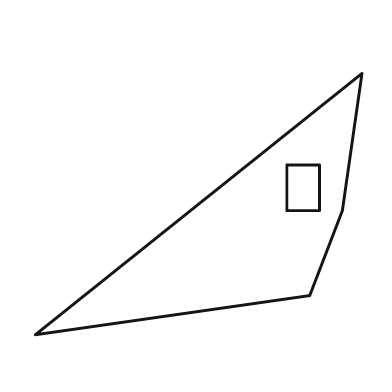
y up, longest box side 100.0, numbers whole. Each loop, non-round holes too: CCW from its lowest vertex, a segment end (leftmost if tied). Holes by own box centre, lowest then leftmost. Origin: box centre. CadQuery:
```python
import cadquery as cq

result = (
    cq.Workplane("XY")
    .moveTo(-50.0, -40.0)
    .lineTo(34.0, -28.0)
    .lineTo(44.0, -2.0)
    .lineTo(50.0, 40.0)
    .close()
    .moveTo(27.0, -2.0)
    .lineTo(37.0, -2.0)
    .lineTo(37.0, 12.0)
    .lineTo(27.0, 12.0)
    .close()
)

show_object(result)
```